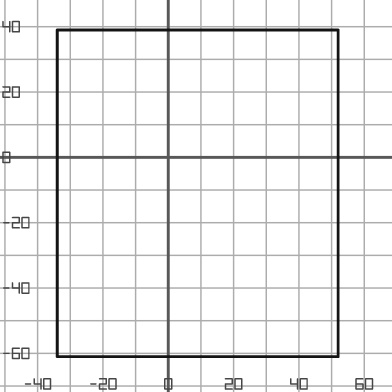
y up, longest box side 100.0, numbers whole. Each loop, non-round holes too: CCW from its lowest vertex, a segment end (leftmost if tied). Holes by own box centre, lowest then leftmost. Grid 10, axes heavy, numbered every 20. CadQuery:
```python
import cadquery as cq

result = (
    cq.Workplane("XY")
    .moveTo(-34.0, -61.0)
    .lineTo(52.0, -61.0)
    .lineTo(52.0, 39.0)
    .lineTo(-34.0, 39.0)
    .close()
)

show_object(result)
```